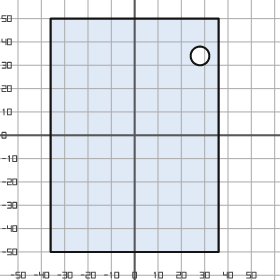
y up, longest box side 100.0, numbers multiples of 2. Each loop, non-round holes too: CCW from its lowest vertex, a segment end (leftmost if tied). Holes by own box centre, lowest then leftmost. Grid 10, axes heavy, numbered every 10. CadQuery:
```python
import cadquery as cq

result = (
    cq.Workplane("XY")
    .moveTo(-36.0, -50.0)
    .lineTo(36.0, -50.0)
    .lineTo(36.0, 50.0)
    .lineTo(-36.0, 50.0)
    .close()
    .moveTo(28.0, 34.0)
    .circle(4.0)
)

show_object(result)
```